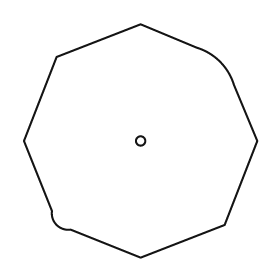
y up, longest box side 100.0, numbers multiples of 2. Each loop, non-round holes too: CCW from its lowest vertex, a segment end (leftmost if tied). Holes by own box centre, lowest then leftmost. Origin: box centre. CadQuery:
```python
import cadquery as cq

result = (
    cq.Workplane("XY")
    .moveTo(0.0, -50.0)
    .lineTo(36.0, -36.0)
    .lineTo(50.0, 0.0)
    .lineTo(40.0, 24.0)
    .threePointArc((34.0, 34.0), (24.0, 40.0))
    .lineTo(0.0, 50.0)
    .lineTo(-36.0, 36.0)
    .lineTo(-50.0, 0.0)
    .lineTo(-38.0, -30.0)
    .threePointArc((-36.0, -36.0), (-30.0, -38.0))
    .close()
    .moveTo(0.0, 0.0)
    .circle(2.0)
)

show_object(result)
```